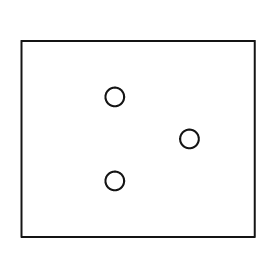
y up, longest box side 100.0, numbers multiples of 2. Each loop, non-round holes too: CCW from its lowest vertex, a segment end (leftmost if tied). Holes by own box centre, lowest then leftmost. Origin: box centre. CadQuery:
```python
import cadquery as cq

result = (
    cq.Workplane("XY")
    .moveTo(-50.0, -42.0)
    .lineTo(50.0, -42.0)
    .lineTo(50.0, 42.0)
    .lineTo(-50.0, 42.0)
    .close()
    .moveTo(-10.0, -18.0)
    .circle(4.0)
    .moveTo(22.0, 0.0)
    .circle(4.0)
    .moveTo(-10.0, 18.0)
    .circle(4.0)
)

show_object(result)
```